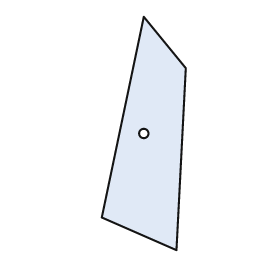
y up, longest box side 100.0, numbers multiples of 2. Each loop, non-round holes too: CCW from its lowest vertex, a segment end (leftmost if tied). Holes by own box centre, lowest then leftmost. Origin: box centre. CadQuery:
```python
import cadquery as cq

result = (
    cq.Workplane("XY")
    .moveTo(14.0, -50.0)
    .lineTo(18.0, 28.0)
    .lineTo(0.0, 50.0)
    .lineTo(-18.0, -36.0)
    .close()
    .moveTo(0.0, 0.0)
    .circle(2.0)
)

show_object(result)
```